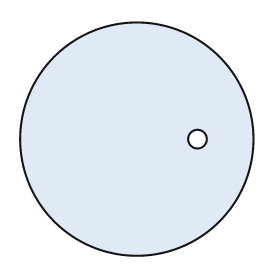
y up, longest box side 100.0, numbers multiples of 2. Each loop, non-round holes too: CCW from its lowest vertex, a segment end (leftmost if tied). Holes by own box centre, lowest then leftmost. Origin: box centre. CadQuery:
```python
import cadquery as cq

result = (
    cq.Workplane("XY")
    .moveTo(0.0, 0.0)
    .circle(50.0)
    .moveTo(26.0, 0.0)
    .circle(4.0)
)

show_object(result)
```